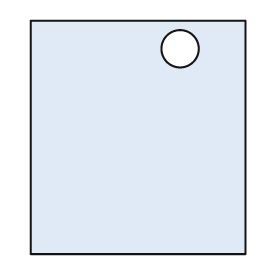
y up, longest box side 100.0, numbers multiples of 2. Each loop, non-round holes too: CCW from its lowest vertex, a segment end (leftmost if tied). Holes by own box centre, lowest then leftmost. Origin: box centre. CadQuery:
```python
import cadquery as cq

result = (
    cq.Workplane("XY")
    .moveTo(-46.0, -50.0)
    .lineTo(46.0, -50.0)
    .lineTo(46.0, 50.0)
    .lineTo(-46.0, 50.0)
    .close()
    .moveTo(18.0, 38.0)
    .circle(8.0)
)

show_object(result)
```